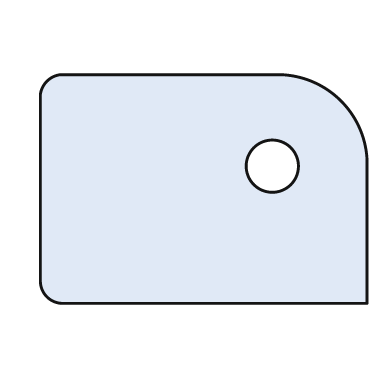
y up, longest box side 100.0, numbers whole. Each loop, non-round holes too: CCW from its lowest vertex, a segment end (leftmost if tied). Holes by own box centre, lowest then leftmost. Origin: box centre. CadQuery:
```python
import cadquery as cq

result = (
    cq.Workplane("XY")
    .moveTo(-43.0, -35.0)
    .lineTo(50.0, -35.0)
    .lineTo(50.0, 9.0)
    .threePointArc((42.0, 27.0), (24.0, 35.0))
    .lineTo(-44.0, 35.0)
    .threePointArc((-48.0, 33.0), (-50.0, 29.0))
    .lineTo(-50.0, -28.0)
    .threePointArc((-48.0, -33.0), (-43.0, -35.0))
    .close()
    .moveTo(21.0, 7.0)
    .circle(8.0)
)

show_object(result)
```